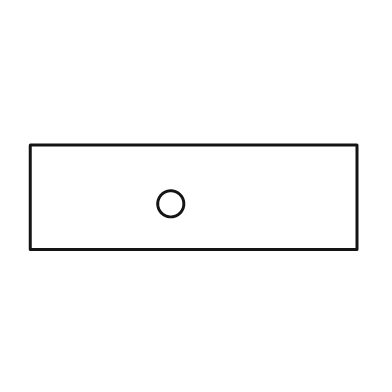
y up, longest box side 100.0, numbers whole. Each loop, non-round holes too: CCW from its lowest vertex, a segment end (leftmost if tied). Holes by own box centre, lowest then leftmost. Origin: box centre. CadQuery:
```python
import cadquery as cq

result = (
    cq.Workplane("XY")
    .moveTo(-50.0, -16.0)
    .lineTo(50.0, -16.0)
    .lineTo(50.0, 16.0)
    .lineTo(-50.0, 16.0)
    .close()
    .moveTo(-7.0, -2.0)
    .circle(4.0)
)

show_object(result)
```